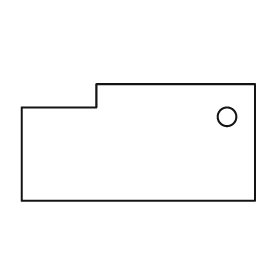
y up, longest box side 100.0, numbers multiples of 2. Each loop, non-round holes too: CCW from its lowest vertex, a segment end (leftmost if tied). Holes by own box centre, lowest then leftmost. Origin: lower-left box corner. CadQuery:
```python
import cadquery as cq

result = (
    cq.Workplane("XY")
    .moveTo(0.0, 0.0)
    .lineTo(100.0, 0.0)
    .lineTo(100.0, 50.0)
    .lineTo(32.0, 50.0)
    .lineTo(32.0, 40.0)
    .lineTo(0.0, 40.0)
    .close()
    .moveTo(88.0, 36.0)
    .circle(4.0)
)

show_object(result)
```